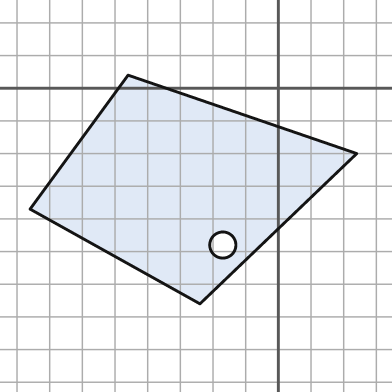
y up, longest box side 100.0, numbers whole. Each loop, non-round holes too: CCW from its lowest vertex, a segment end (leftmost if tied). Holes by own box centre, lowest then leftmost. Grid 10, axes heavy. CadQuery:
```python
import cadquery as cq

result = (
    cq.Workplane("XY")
    .moveTo(-24.0, -66.0)
    .lineTo(24.0, -20.0)
    .lineTo(-46.0, 4.0)
    .lineTo(-76.0, -37.0)
    .close()
    .moveTo(-17.0, -48.0)
    .circle(4.0)
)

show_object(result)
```